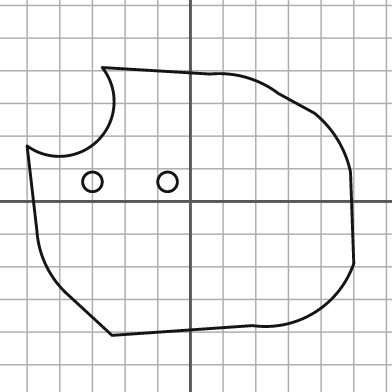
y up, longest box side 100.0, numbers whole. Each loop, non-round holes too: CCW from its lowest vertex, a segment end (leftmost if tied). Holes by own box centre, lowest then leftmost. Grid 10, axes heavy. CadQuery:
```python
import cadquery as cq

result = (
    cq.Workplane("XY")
    .moveTo(-24.0, -41.0)
    .lineTo(19.0, -38.0)
    .threePointArc((38.0, -34.0), (50.0, -19.0))
    .lineTo(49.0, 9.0)
    .threePointArc((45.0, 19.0), (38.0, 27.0))
    .lineTo(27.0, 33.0)
    .threePointArc((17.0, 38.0), (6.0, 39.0))
    .lineTo(-27.0, 41.0)
    .threePointArc((-28.0, 19.0), (-50.0, 17.0))
    .lineTo(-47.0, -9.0)
    .threePointArc((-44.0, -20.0), (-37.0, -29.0))
    .close()
    .moveTo(-30.0, 6.0)
    .circle(3.0)
    .moveTo(-7.0, 6.0)
    .circle(3.0)
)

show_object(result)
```